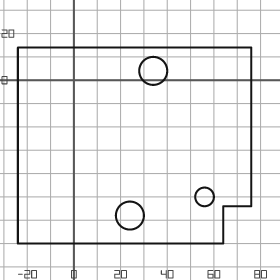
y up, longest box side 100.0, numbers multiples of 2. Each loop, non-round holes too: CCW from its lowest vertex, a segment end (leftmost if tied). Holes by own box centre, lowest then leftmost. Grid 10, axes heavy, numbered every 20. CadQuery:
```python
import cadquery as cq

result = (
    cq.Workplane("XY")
    .moveTo(-24.0, -70.0)
    .lineTo(64.0, -70.0)
    .lineTo(64.0, -54.0)
    .lineTo(76.0, -54.0)
    .lineTo(76.0, 14.0)
    .lineTo(-24.0, 14.0)
    .close()
    .moveTo(24.0, -58.0)
    .circle(6.0)
    .moveTo(56.0, -50.0)
    .circle(4.0)
    .moveTo(34.0, 4.0)
    .circle(6.0)
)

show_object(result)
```